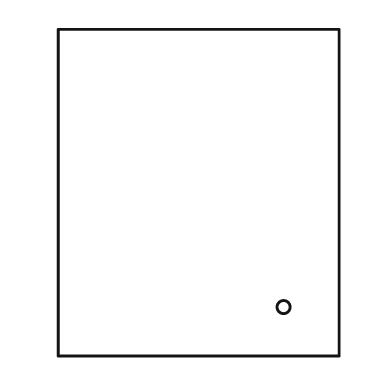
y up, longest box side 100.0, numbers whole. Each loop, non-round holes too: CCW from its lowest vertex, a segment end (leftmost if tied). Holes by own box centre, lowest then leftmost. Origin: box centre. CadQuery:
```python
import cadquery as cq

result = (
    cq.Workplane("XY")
    .moveTo(-43.0, -50.0)
    .lineTo(43.0, -50.0)
    .lineTo(43.0, 50.0)
    .lineTo(-43.0, 50.0)
    .close()
    .moveTo(26.0, -35.0)
    .circle(2.0)
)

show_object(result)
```